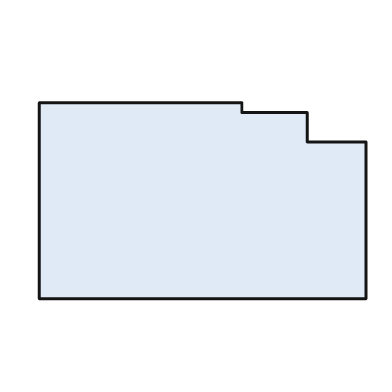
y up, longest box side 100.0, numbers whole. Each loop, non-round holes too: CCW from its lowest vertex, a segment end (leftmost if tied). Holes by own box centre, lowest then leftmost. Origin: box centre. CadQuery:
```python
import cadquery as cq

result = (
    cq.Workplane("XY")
    .moveTo(-50.0, -30.0)
    .lineTo(50.0, -30.0)
    .lineTo(50.0, 18.0)
    .lineTo(32.0, 18.0)
    .lineTo(32.0, 27.0)
    .lineTo(12.0, 27.0)
    .lineTo(12.0, 30.0)
    .lineTo(-50.0, 30.0)
    .close()
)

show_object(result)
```